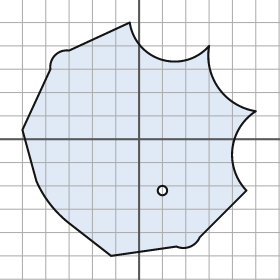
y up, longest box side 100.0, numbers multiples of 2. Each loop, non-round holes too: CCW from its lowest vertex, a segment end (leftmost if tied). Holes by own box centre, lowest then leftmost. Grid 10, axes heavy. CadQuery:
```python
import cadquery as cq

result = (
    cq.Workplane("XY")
    .moveTo(-12.0, -50.0)
    .lineTo(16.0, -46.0)
    .threePointArc((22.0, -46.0), (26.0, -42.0))
    .lineTo(46.0, -22.0)
    .threePointArc((40.0, -4.0), (50.0, 12.0))
    .threePointArc((34.0, 22.0), (30.0, 40.0))
    .threePointArc((10.0, 34.0), (-4.0, 50.0))
    .lineTo(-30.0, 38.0)
    .threePointArc((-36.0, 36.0), (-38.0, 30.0))
    .lineTo(-50.0, 4.0)
    .lineTo(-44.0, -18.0)
    .threePointArc((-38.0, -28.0), (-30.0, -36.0))
    .close()
    .moveTo(10.0, -22.0)
    .circle(2.0)
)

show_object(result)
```